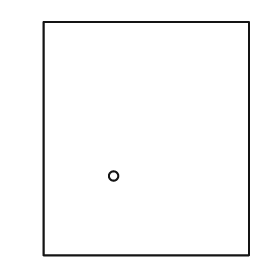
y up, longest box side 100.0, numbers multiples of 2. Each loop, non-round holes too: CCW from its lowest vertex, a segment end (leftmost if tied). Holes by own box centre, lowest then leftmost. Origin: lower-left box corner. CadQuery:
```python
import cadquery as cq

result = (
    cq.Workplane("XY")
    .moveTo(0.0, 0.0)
    .lineTo(88.0, 0.0)
    .lineTo(88.0, 100.0)
    .lineTo(0.0, 100.0)
    .close()
    .moveTo(30.0, 34.0)
    .circle(2.0)
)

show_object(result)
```